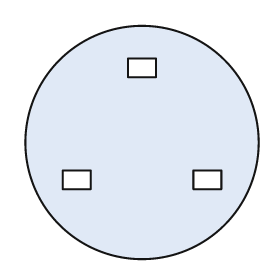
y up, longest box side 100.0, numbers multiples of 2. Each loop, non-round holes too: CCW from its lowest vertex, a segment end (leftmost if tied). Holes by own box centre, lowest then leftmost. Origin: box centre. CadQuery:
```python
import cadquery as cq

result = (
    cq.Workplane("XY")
    .moveTo(0.0, 0.0)
    .circle(50.0)
    .moveTo(-34.0, -20.0)
    .lineTo(-22.0, -20.0)
    .lineTo(-22.0, -12.0)
    .lineTo(-34.0, -12.0)
    .close()
    .moveTo(22.0, -20.0)
    .lineTo(34.0, -20.0)
    .lineTo(34.0, -12.0)
    .lineTo(22.0, -12.0)
    .close()
    .moveTo(-6.0, 28.0)
    .lineTo(6.0, 28.0)
    .lineTo(6.0, 36.0)
    .lineTo(-6.0, 36.0)
    .close()
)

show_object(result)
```